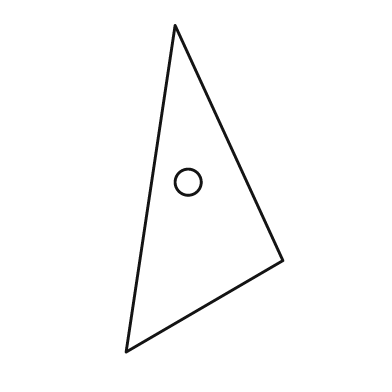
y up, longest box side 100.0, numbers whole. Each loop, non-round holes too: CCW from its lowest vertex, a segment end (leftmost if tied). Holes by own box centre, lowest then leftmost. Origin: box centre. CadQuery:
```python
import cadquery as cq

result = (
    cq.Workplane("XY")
    .moveTo(-24.0, -50.0)
    .lineTo(24.0, -22.0)
    .lineTo(-9.0, 50.0)
    .close()
    .moveTo(-5.0, 2.0)
    .circle(4.0)
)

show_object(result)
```